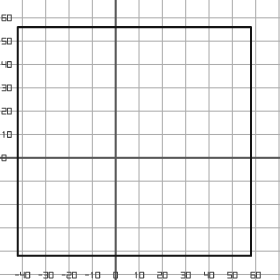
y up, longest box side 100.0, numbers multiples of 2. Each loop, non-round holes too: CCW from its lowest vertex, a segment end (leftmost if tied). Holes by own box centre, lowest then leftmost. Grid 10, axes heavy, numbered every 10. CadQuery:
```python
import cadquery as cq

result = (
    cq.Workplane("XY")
    .moveTo(-42.0, -42.0)
    .lineTo(58.0, -42.0)
    .lineTo(58.0, 56.0)
    .lineTo(-42.0, 56.0)
    .close()
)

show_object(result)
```